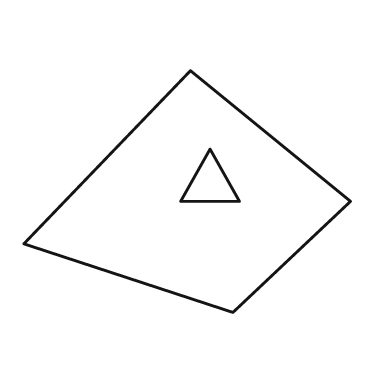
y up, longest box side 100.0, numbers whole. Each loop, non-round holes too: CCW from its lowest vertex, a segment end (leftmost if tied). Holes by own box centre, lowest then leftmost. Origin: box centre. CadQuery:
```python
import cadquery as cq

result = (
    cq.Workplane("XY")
    .moveTo(14.0, -37.0)
    .lineTo(50.0, -3.0)
    .lineTo(1.0, 37.0)
    .lineTo(-50.0, -16.0)
    .close()
    .moveTo(-2.0, -3.0)
    .lineTo(16.0, -3.0)
    .lineTo(7.0, 13.0)
    .close()
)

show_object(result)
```